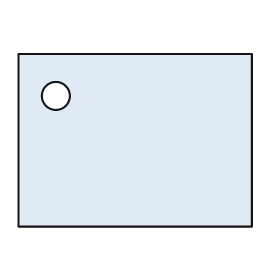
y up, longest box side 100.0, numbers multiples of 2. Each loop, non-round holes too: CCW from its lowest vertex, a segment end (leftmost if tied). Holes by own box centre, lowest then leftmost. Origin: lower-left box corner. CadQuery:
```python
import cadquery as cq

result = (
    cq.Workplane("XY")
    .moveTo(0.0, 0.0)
    .lineTo(100.0, 0.0)
    .lineTo(100.0, 74.0)
    .lineTo(0.0, 74.0)
    .close()
    .moveTo(16.0, 56.0)
    .circle(6.0)
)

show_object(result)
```